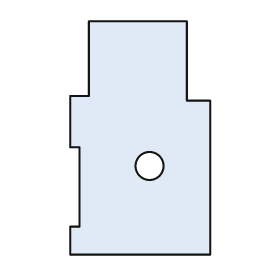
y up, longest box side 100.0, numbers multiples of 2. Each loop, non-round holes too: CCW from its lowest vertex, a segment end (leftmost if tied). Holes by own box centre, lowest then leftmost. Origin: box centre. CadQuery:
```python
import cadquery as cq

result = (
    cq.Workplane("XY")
    .moveTo(-30.0, -50.0)
    .lineTo(30.0, -50.0)
    .lineTo(30.0, 16.0)
    .lineTo(20.0, 16.0)
    .lineTo(20.0, 50.0)
    .lineTo(-22.0, 50.0)
    .lineTo(-22.0, 18.0)
    .lineTo(-30.0, 18.0)
    .lineTo(-30.0, -4.0)
    .lineTo(-26.0, -4.0)
    .lineTo(-26.0, -38.0)
    .lineTo(-30.0, -38.0)
    .close()
    .moveTo(4.0, -12.0)
    .circle(6.0)
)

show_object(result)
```